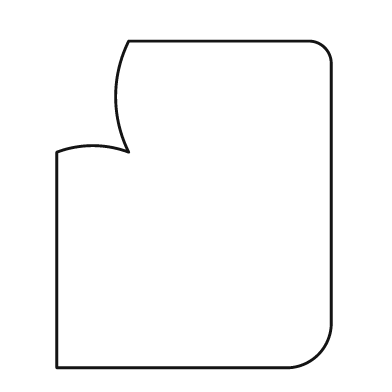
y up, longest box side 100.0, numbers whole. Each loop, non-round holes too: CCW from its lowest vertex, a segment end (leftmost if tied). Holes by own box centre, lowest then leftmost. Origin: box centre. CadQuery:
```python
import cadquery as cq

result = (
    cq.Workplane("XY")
    .moveTo(-42.0, -50.0)
    .lineTo(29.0, -50.0)
    .threePointArc((38.0, -46.0), (42.0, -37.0))
    .lineTo(42.0, 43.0)
    .threePointArc((40.0, 48.0), (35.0, 50.0))
    .lineTo(-20.0, 50.0)
    .threePointArc((-24.0, 33.0), (-20.0, 16.0))
    .threePointArc((-31.0, 18.0), (-42.0, 16.0))
    .close()
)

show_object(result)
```